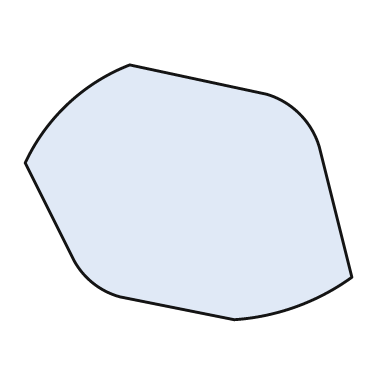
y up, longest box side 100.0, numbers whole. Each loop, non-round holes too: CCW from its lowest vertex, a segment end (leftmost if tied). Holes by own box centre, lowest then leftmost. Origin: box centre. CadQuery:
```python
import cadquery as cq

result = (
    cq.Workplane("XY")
    .moveTo(14.0, -39.0)
    .threePointArc((33.0, -35.0), (50.0, -26.0))
    .lineTo(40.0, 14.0)
    .threePointArc((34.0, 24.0), (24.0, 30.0))
    .lineTo(-18.0, 39.0)
    .threePointArc((-37.0, 27.0), (-50.0, 9.0))
    .lineTo(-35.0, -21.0)
    .threePointArc((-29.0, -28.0), (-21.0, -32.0))
    .close()
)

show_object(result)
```